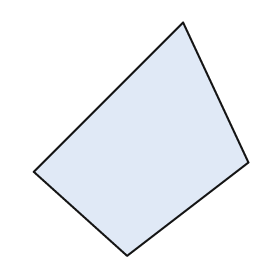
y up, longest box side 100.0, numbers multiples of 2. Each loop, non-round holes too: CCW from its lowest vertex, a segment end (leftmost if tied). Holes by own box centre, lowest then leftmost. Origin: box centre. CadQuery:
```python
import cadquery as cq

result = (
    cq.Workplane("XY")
    .moveTo(-6.0, -50.0)
    .lineTo(46.0, -10.0)
    .lineTo(18.0, 50.0)
    .lineTo(-46.0, -14.0)
    .close()
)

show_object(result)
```